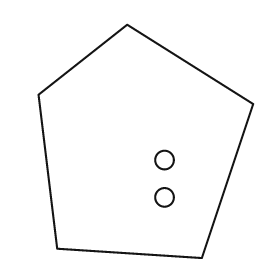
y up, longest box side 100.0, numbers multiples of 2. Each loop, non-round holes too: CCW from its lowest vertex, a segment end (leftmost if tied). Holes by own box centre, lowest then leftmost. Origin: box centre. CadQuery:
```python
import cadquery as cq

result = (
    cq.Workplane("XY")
    .moveTo(24.0, -50.0)
    .lineTo(46.0, 16.0)
    .lineTo(-8.0, 50.0)
    .lineTo(-46.0, 20.0)
    .lineTo(-38.0, -46.0)
    .close()
    .moveTo(8.0, -24.0)
    .circle(4.0)
    .moveTo(8.0, -8.0)
    .circle(4.0)
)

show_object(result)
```